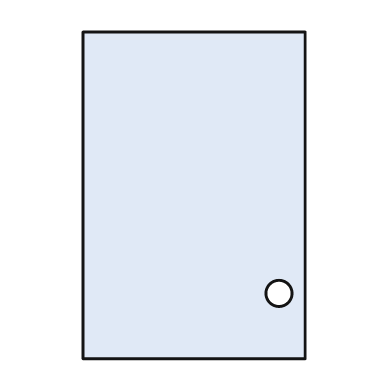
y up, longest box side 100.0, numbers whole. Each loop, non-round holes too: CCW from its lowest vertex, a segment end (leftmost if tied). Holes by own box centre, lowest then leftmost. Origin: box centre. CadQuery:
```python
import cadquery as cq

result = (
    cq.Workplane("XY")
    .moveTo(-34.0, -50.0)
    .lineTo(34.0, -50.0)
    .lineTo(34.0, 50.0)
    .lineTo(-34.0, 50.0)
    .close()
    .moveTo(26.0, -30.0)
    .circle(4.0)
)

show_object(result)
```